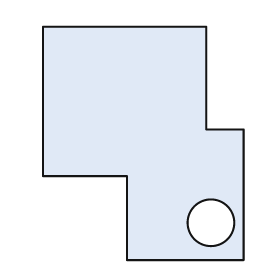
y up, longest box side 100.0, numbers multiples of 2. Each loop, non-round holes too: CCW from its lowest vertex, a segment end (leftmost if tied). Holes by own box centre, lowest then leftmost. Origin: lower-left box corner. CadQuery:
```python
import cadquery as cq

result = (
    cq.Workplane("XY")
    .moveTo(36.0, 0.0)
    .lineTo(86.0, 0.0)
    .lineTo(86.0, 56.0)
    .lineTo(70.0, 56.0)
    .lineTo(70.0, 100.0)
    .lineTo(0.0, 100.0)
    .lineTo(0.0, 36.0)
    .lineTo(36.0, 36.0)
    .close()
    .moveTo(72.0, 16.0)
    .circle(10.0)
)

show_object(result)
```